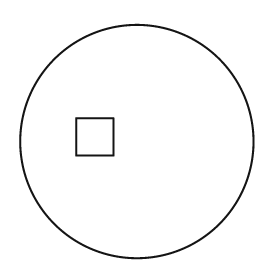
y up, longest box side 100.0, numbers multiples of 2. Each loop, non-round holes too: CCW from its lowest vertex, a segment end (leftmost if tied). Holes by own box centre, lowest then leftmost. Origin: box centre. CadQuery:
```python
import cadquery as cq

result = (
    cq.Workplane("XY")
    .moveTo(0.0, 0.0)
    .circle(50.0)
    .moveTo(-26.0, -6.0)
    .lineTo(-10.0, -6.0)
    .lineTo(-10.0, 10.0)
    .lineTo(-26.0, 10.0)
    .close()
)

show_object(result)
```